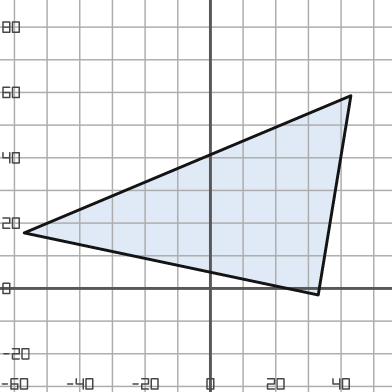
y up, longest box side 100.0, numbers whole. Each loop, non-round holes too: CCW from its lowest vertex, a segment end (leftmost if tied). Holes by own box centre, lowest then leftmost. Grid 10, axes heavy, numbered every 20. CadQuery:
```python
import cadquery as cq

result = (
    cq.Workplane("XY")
    .moveTo(33.0, -2.0)
    .lineTo(43.0, 59.0)
    .lineTo(-57.0, 17.0)
    .close()
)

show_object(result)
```